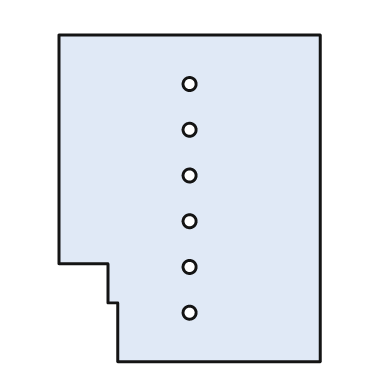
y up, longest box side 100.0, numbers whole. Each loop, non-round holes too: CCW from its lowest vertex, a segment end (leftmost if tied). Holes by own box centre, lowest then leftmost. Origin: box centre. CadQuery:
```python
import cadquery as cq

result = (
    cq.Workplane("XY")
    .moveTo(-22.0, -50.0)
    .lineTo(40.0, -50.0)
    .lineTo(40.0, 50.0)
    .lineTo(-40.0, 50.0)
    .lineTo(-40.0, -20.0)
    .lineTo(-25.0, -20.0)
    .lineTo(-25.0, -32.0)
    .lineTo(-22.0, -32.0)
    .close()
    .moveTo(0.0, -35.0)
    .circle(2.0)
    .moveTo(0.0, -21.0)
    .circle(2.0)
    .moveTo(0.0, -7.0)
    .circle(2.0)
    .moveTo(0.0, 7.0)
    .circle(2.0)
    .moveTo(0.0, 21.0)
    .circle(2.0)
    .moveTo(0.0, 35.0)
    .circle(2.0)
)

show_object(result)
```